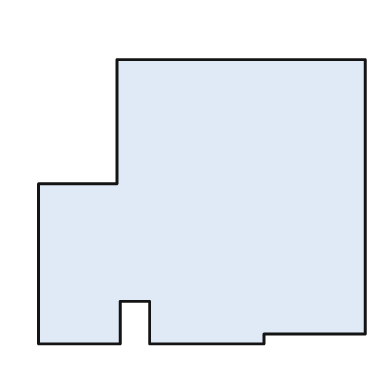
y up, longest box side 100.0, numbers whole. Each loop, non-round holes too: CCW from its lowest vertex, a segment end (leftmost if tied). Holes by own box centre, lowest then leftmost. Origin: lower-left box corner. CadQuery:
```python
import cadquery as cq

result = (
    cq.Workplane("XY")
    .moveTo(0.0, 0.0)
    .lineTo(25.0, 0.0)
    .lineTo(25.0, 13.0)
    .lineTo(34.0, 13.0)
    .lineTo(34.0, 0.0)
    .lineTo(69.0, 0.0)
    .lineTo(69.0, 3.0)
    .lineTo(100.0, 3.0)
    .lineTo(100.0, 87.0)
    .lineTo(24.0, 87.0)
    .lineTo(24.0, 49.0)
    .lineTo(0.0, 49.0)
    .close()
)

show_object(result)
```